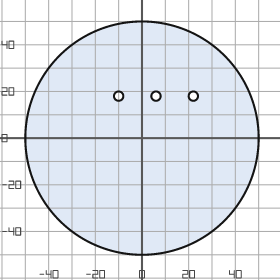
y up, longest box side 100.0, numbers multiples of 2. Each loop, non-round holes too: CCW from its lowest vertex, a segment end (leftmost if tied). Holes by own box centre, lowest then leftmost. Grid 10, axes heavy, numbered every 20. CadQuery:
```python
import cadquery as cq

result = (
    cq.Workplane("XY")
    .moveTo(0.0, 0.0)
    .circle(50.0)
    .moveTo(-10.0, 18.0)
    .circle(2.0)
    .moveTo(6.0, 18.0)
    .circle(2.0)
    .moveTo(22.0, 18.0)
    .circle(2.0)
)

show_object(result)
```